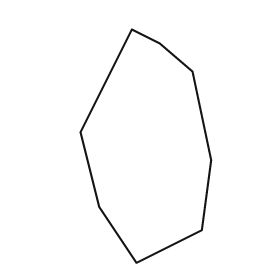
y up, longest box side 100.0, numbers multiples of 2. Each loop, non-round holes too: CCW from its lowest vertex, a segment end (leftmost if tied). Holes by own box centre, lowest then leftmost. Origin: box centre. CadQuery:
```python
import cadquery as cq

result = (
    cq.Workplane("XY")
    .moveTo(-4.0, -50.0)
    .lineTo(24.0, -36.0)
    .lineTo(28.0, -6.0)
    .lineTo(20.0, 32.0)
    .lineTo(6.0, 44.0)
    .lineTo(-6.0, 50.0)
    .lineTo(-28.0, 6.0)
    .lineTo(-20.0, -26.0)
    .close()
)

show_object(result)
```